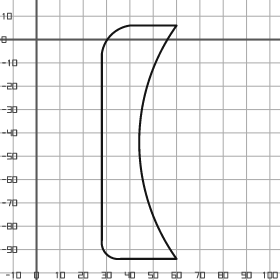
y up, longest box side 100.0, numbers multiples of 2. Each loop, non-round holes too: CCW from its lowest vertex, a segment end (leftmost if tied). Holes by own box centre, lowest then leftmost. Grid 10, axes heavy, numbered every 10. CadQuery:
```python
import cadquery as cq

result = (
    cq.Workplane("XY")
    .moveTo(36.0, -94.0)
    .lineTo(60.0, -94.0)
    .threePointArc((44.0, -44.0), (60.0, 6.0))
    .lineTo(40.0, 6.0)
    .threePointArc((32.0, 2.0), (28.0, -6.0))
    .lineTo(28.0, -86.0)
    .threePointArc((30.0, -92.0), (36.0, -94.0))
    .close()
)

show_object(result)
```